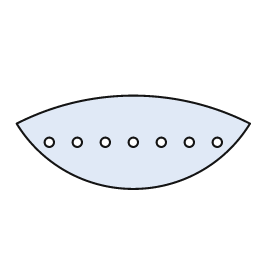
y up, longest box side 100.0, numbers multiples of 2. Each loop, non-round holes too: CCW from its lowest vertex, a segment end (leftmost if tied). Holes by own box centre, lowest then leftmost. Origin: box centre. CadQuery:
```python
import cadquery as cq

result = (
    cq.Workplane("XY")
    .moveTo(-50.0, 8.0)
    .threePointArc((0.0, -20.0), (50.0, 8.0))
    .threePointArc((0.0, 20.0), (-50.0, 8.0))
    .close()
    .moveTo(-36.0, 0.0)
    .circle(2.0)
    .moveTo(-24.0, 0.0)
    .circle(2.0)
    .moveTo(-12.0, 0.0)
    .circle(2.0)
    .moveTo(0.0, 0.0)
    .circle(2.0)
    .moveTo(12.0, 0.0)
    .circle(2.0)
    .moveTo(24.0, 0.0)
    .circle(2.0)
    .moveTo(36.0, 0.0)
    .circle(2.0)
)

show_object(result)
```